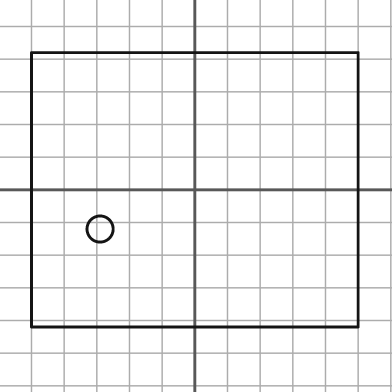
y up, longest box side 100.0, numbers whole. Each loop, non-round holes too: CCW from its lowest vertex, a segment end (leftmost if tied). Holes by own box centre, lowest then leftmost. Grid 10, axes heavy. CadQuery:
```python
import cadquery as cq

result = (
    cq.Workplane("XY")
    .moveTo(-50.0, -42.0)
    .lineTo(50.0, -42.0)
    .lineTo(50.0, 42.0)
    .lineTo(-50.0, 42.0)
    .close()
    .moveTo(-29.0, -12.0)
    .circle(4.0)
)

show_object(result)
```